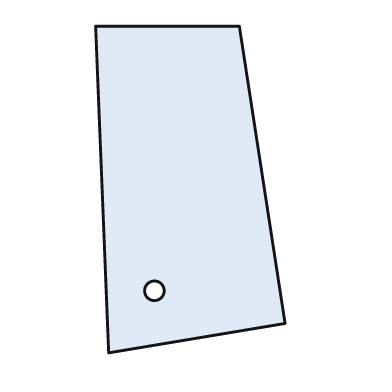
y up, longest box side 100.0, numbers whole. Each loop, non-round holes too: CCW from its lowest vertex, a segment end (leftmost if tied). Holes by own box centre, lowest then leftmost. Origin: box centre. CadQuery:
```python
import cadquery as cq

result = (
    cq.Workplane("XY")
    .moveTo(-25.0, -50.0)
    .lineTo(29.0, -41.0)
    .lineTo(15.0, 50.0)
    .lineTo(-29.0, 50.0)
    .close()
    .moveTo(-11.0, -31.0)
    .circle(3.0)
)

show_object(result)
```